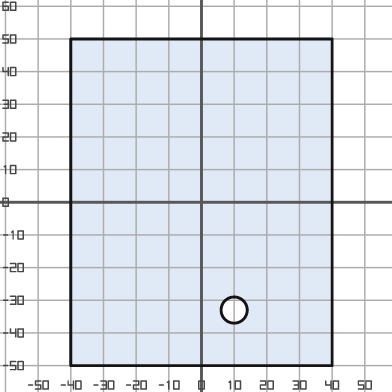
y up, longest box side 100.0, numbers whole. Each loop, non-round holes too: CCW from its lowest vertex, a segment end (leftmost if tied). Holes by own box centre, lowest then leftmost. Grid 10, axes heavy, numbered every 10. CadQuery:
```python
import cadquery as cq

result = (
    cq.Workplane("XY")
    .moveTo(-40.0, -50.0)
    .lineTo(40.0, -50.0)
    .lineTo(40.0, 50.0)
    .lineTo(-40.0, 50.0)
    .close()
    .moveTo(10.0, -33.0)
    .circle(4.0)
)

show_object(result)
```